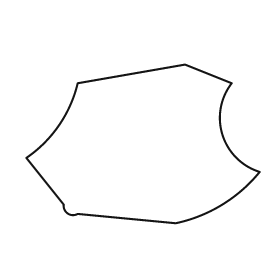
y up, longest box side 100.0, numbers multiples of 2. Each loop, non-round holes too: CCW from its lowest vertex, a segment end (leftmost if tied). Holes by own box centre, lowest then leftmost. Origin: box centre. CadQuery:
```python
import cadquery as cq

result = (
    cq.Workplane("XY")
    .moveTo(14.0, -34.0)
    .threePointArc((34.0, -26.0), (50.0, -12.0))
    .threePointArc((34.0, 4.0), (38.0, 26.0))
    .lineTo(18.0, 34.0)
    .lineTo(-28.0, 26.0)
    .threePointArc((-36.0, 8.0), (-50.0, -6.0))
    .lineTo(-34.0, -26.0)
    .threePointArc((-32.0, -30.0), (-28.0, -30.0))
    .close()
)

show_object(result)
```